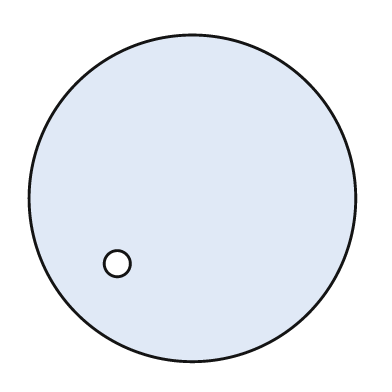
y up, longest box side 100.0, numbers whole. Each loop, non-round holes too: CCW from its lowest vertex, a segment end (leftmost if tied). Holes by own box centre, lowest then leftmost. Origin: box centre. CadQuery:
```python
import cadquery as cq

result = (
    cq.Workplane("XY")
    .moveTo(0.0, 0.0)
    .circle(50.0)
    .moveTo(-23.0, -20.0)
    .circle(4.0)
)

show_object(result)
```